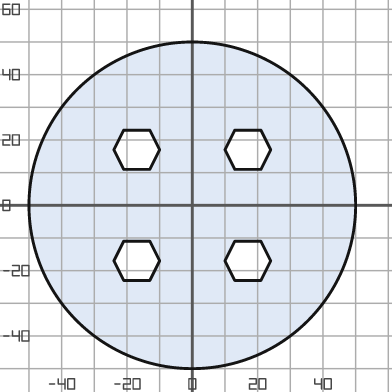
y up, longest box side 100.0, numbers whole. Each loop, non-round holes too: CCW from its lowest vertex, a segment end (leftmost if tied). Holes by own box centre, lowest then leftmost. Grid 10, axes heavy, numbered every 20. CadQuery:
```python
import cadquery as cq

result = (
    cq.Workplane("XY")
    .moveTo(0.0, 0.0)
    .circle(50.0)
    .moveTo(-21.0, -23.0)
    .lineTo(-13.0, -23.0)
    .lineTo(-10.0, -17.0)
    .lineTo(-13.0, -11.0)
    .lineTo(-21.0, -11.0)
    .lineTo(-24.0, -17.0)
    .close()
    .moveTo(13.0, -23.0)
    .lineTo(21.0, -23.0)
    .lineTo(24.0, -17.0)
    .lineTo(21.0, -11.0)
    .lineTo(13.0, -11.0)
    .lineTo(10.0, -17.0)
    .close()
    .moveTo(-21.0, 11.0)
    .lineTo(-13.0, 11.0)
    .lineTo(-10.0, 17.0)
    .lineTo(-13.0, 23.0)
    .lineTo(-21.0, 23.0)
    .lineTo(-24.0, 17.0)
    .close()
    .moveTo(13.0, 11.0)
    .lineTo(21.0, 11.0)
    .lineTo(24.0, 17.0)
    .lineTo(21.0, 23.0)
    .lineTo(13.0, 23.0)
    .lineTo(10.0, 17.0)
    .close()
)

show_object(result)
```